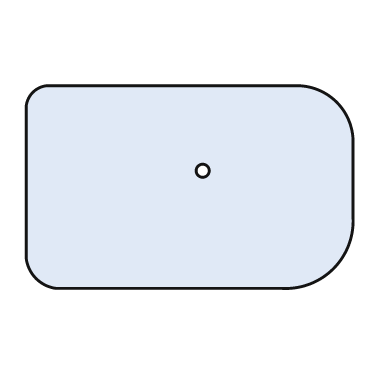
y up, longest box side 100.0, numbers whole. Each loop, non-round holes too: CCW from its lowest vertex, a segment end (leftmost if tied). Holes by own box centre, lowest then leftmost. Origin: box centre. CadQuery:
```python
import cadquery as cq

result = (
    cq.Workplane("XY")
    .moveTo(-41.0, -31.0)
    .lineTo(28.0, -31.0)
    .threePointArc((44.0, -25.0), (50.0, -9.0))
    .lineTo(50.0, 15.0)
    .threePointArc((45.0, 26.0), (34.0, 31.0))
    .lineTo(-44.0, 31.0)
    .threePointArc((-48.0, 29.0), (-50.0, 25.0))
    .lineTo(-50.0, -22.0)
    .threePointArc((-47.0, -28.0), (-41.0, -31.0))
    .close()
    .moveTo(4.0, 5.0)
    .circle(2.0)
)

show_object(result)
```